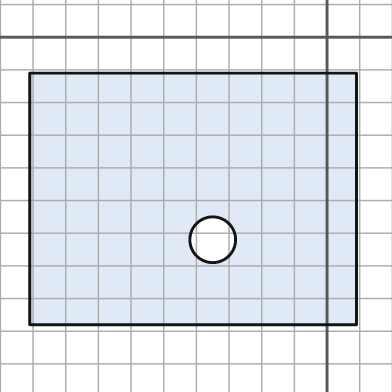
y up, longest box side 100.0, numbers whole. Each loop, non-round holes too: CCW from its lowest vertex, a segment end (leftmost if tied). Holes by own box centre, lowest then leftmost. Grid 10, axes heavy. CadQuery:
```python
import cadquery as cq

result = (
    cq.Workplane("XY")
    .moveTo(-91.0, -88.0)
    .lineTo(9.0, -88.0)
    .lineTo(9.0, -11.0)
    .lineTo(-91.0, -11.0)
    .close()
    .moveTo(-35.0, -62.0)
    .circle(7.0)
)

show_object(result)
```